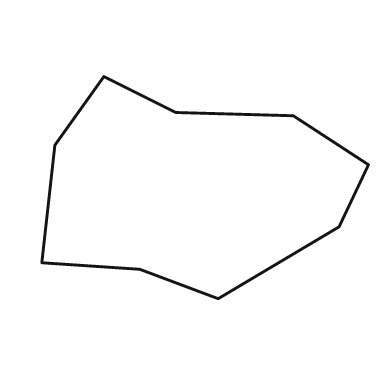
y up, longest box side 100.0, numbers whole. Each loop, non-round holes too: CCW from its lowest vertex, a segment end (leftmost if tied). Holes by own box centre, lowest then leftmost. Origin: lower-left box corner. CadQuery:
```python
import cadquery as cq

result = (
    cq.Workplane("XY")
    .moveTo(54.0, 0.0)
    .lineTo(91.0, 22.0)
    .lineTo(100.0, 41.0)
    .lineTo(77.0, 56.0)
    .lineTo(41.0, 57.0)
    .lineTo(19.0, 68.0)
    .lineTo(4.0, 47.0)
    .lineTo(0.0, 11.0)
    .lineTo(30.0, 9.0)
    .close()
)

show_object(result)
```